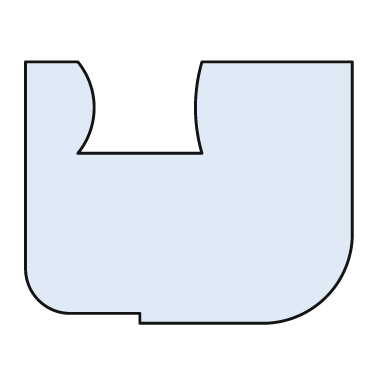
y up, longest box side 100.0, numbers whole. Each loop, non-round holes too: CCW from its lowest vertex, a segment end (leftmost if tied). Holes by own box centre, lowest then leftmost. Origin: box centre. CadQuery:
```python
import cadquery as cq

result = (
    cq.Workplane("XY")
    .moveTo(-15.0, -40.0)
    .lineTo(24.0, -40.0)
    .threePointArc((42.0, -32.0), (50.0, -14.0))
    .lineTo(50.0, 40.0)
    .lineTo(4.0, 40.0)
    .threePointArc((2.0, 26.0), (4.0, 12.0))
    .lineTo(-34.0, 12.0)
    .threePointArc((-29.0, 26.0), (-34.0, 40.0))
    .lineTo(-50.0, 40.0)
    .lineTo(-50.0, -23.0)
    .threePointArc((-46.0, -33.0), (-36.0, -37.0))
    .lineTo(-15.0, -37.0)
    .close()
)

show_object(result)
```